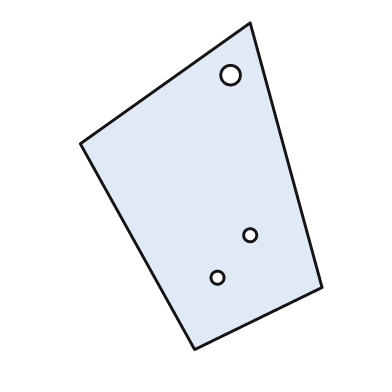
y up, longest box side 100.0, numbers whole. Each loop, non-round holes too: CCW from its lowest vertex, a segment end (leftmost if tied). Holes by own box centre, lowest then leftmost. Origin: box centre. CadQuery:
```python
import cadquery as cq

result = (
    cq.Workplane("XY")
    .moveTo(-2.0, -50.0)
    .lineTo(37.0, -31.0)
    .lineTo(15.0, 50.0)
    .lineTo(-37.0, 13.0)
    .close()
    .moveTo(5.0, -28.0)
    .circle(2.0)
    .moveTo(15.0, -15.0)
    .circle(2.0)
    .moveTo(9.0, 34.0)
    .circle(3.0)
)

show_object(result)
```